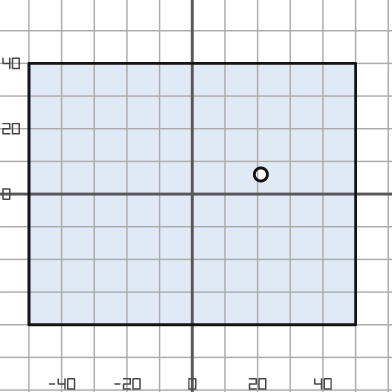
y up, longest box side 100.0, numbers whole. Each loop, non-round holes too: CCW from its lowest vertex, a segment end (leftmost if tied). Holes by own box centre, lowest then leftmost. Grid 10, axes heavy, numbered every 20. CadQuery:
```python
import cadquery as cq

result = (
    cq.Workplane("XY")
    .moveTo(-50.0, -40.0)
    .lineTo(50.0, -40.0)
    .lineTo(50.0, 40.0)
    .lineTo(-50.0, 40.0)
    .close()
    .moveTo(21.0, 6.0)
    .circle(2.0)
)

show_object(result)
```